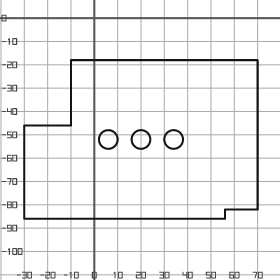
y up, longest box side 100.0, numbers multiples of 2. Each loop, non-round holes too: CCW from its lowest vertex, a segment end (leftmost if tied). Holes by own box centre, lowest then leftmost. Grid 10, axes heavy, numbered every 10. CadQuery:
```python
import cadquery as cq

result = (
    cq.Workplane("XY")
    .moveTo(-30.0, -86.0)
    .lineTo(56.0, -86.0)
    .lineTo(56.0, -82.0)
    .lineTo(70.0, -82.0)
    .lineTo(70.0, -18.0)
    .lineTo(-10.0, -18.0)
    .lineTo(-10.0, -46.0)
    .lineTo(-30.0, -46.0)
    .close()
    .moveTo(6.0, -52.0)
    .circle(4.0)
    .moveTo(20.0, -52.0)
    .circle(4.0)
    .moveTo(34.0, -52.0)
    .circle(4.0)
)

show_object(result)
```